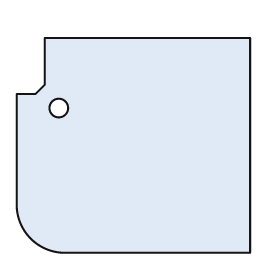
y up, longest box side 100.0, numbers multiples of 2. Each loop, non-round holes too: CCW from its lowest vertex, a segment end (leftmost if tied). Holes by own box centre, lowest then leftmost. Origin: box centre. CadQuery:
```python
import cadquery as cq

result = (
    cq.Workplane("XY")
    .moveTo(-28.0, -46.0)
    .lineTo(50.0, -46.0)
    .lineTo(50.0, 46.0)
    .lineTo(-38.0, 46.0)
    .lineTo(-38.0, 26.0)
    .lineTo(-42.0, 22.0)
    .lineTo(-50.0, 22.0)
    .lineTo(-50.0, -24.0)
    .threePointArc((-44.0, -40.0), (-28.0, -46.0))
    .close()
    .moveTo(-32.0, 16.0)
    .circle(4.0)
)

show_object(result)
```